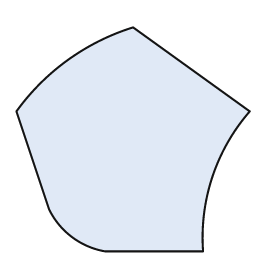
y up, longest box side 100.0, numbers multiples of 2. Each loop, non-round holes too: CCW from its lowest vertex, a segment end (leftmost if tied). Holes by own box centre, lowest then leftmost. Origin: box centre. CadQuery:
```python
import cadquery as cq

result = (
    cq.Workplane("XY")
    .moveTo(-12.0, -48.0)
    .lineTo(30.0, -48.0)
    .threePointArc((34.0, -16.0), (50.0, 12.0))
    .lineTo(0.0, 48.0)
    .threePointArc((-28.0, 34.0), (-50.0, 12.0))
    .lineTo(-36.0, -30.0)
    .threePointArc((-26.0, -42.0), (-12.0, -48.0))
    .close()
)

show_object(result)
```